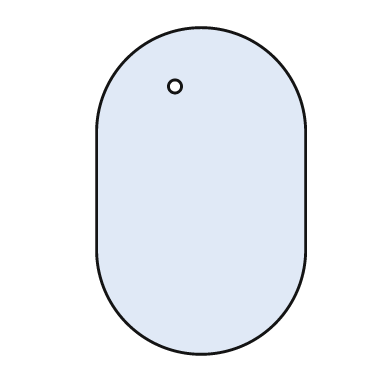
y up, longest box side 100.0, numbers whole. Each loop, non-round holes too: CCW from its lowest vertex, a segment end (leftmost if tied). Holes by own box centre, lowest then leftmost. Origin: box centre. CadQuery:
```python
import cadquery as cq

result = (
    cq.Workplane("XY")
    .moveTo(-32.0, -18.0)
    .threePointArc((0.0, -50.0), (32.0, -18.0))
    .lineTo(32.0, 18.0)
    .threePointArc((0.0, 50.0), (-32.0, 18.0))
    .close()
    .moveTo(-8.0, 32.0)
    .circle(2.0)
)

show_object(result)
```